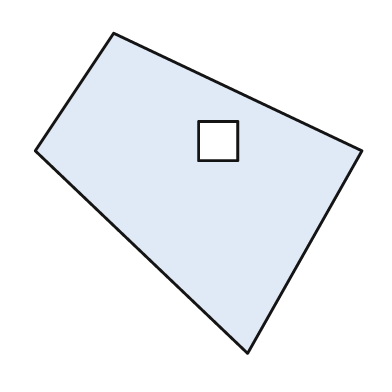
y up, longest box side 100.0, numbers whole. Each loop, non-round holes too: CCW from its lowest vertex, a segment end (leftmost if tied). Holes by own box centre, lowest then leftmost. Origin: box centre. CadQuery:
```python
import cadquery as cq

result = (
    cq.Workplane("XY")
    .moveTo(15.0, -49.0)
    .lineTo(50.0, 13.0)
    .lineTo(-26.0, 49.0)
    .lineTo(-50.0, 13.0)
    .close()
    .moveTo(0.0, 10.0)
    .lineTo(12.0, 10.0)
    .lineTo(12.0, 22.0)
    .lineTo(0.0, 22.0)
    .close()
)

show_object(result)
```